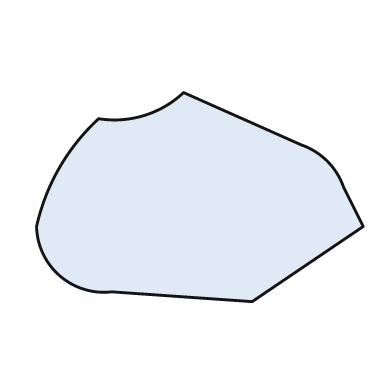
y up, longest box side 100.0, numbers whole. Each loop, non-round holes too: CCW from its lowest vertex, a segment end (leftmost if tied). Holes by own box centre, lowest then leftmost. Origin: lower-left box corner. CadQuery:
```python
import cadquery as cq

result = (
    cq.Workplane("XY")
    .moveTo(66.0, 0.0)
    .lineTo(100.0, 23.0)
    .lineTo(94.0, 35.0)
    .threePointArc((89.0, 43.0), (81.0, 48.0))
    .lineTo(45.0, 64.0)
    .threePointArc((33.0, 57.0), (19.0, 56.0))
    .threePointArc((7.0, 41.0), (0.0, 23.0))
    .threePointArc((7.0, 8.0), (23.0, 3.0))
    .close()
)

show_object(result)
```